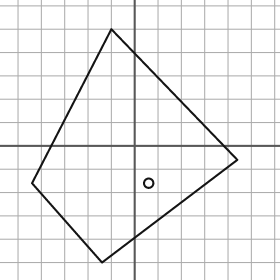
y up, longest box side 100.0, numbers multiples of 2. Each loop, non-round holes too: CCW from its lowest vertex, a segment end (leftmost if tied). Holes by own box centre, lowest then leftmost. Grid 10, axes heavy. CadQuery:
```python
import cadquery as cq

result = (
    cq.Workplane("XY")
    .moveTo(-14.0, -50.0)
    .lineTo(44.0, -6.0)
    .lineTo(-10.0, 50.0)
    .lineTo(-44.0, -16.0)
    .close()
    .moveTo(6.0, -16.0)
    .circle(2.0)
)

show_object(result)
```